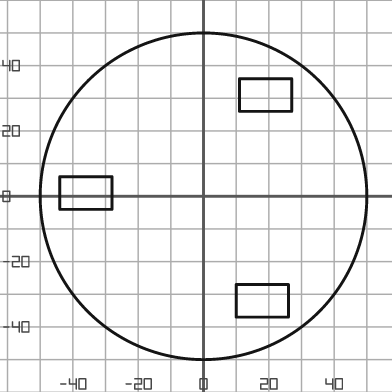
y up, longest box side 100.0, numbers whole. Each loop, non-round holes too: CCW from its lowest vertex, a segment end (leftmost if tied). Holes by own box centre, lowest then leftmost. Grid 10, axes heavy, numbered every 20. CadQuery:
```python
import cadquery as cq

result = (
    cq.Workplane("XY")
    .moveTo(0.0, 0.0)
    .circle(50.0)
    .moveTo(10.0, -37.0)
    .lineTo(26.0, -37.0)
    .lineTo(26.0, -27.0)
    .lineTo(10.0, -27.0)
    .close()
    .moveTo(-44.0, -4.0)
    .lineTo(-28.0, -4.0)
    .lineTo(-28.0, 6.0)
    .lineTo(-44.0, 6.0)
    .close()
    .moveTo(11.0, 26.0)
    .lineTo(27.0, 26.0)
    .lineTo(27.0, 36.0)
    .lineTo(11.0, 36.0)
    .close()
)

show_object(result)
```